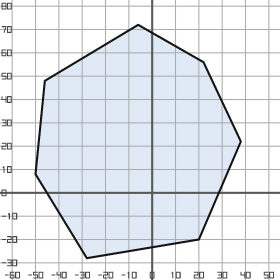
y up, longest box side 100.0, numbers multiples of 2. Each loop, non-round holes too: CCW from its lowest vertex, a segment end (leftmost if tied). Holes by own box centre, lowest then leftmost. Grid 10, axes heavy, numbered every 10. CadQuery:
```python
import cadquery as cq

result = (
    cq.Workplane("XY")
    .moveTo(-28.0, -28.0)
    .lineTo(20.0, -20.0)
    .lineTo(38.0, 22.0)
    .lineTo(22.0, 56.0)
    .lineTo(-6.0, 72.0)
    .lineTo(-46.0, 48.0)
    .lineTo(-50.0, 8.0)
    .close()
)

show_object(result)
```